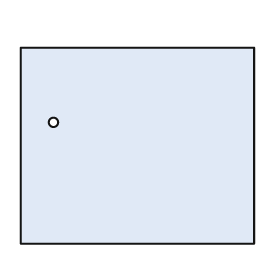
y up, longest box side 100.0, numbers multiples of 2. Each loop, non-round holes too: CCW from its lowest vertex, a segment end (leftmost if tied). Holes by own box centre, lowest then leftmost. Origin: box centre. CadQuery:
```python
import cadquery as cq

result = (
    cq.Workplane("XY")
    .moveTo(-50.0, -42.0)
    .lineTo(50.0, -42.0)
    .lineTo(50.0, 42.0)
    .lineTo(-50.0, 42.0)
    .close()
    .moveTo(-36.0, 10.0)
    .circle(2.0)
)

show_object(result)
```